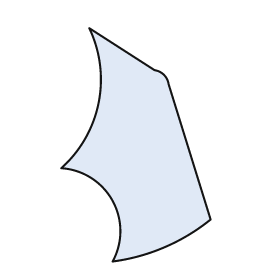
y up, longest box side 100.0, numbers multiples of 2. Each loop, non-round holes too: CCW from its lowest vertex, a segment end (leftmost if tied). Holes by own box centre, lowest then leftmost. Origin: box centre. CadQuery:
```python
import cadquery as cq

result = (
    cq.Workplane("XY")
    .moveTo(-10.0, -50.0)
    .threePointArc((12.0, -44.0), (32.0, -32.0))
    .lineTo(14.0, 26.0)
    .threePointArc((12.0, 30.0), (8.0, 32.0))
    .lineTo(-20.0, 50.0)
    .threePointArc((-16.0, 18.0), (-32.0, -10.0))
    .threePointArc((-10.0, -24.0), (-10.0, -50.0))
    .close()
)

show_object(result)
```